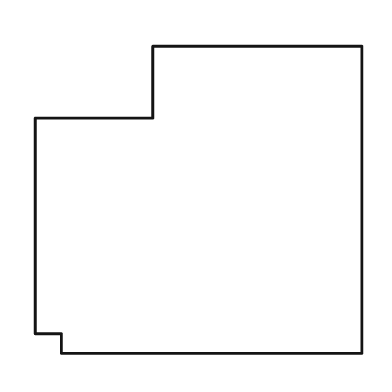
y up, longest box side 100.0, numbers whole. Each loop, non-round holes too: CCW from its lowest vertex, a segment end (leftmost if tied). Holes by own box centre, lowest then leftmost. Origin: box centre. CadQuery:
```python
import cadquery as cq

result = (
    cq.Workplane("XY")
    .moveTo(-42.0, -47.0)
    .lineTo(50.0, -47.0)
    .lineTo(50.0, 47.0)
    .lineTo(-14.0, 47.0)
    .lineTo(-14.0, 25.0)
    .lineTo(-50.0, 25.0)
    .lineTo(-50.0, -41.0)
    .lineTo(-42.0, -41.0)
    .close()
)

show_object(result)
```